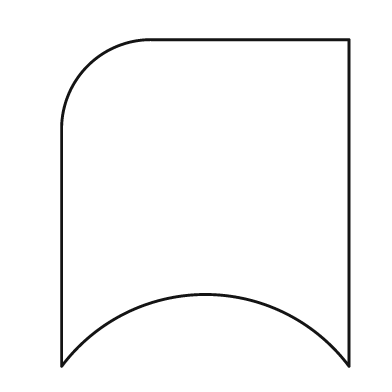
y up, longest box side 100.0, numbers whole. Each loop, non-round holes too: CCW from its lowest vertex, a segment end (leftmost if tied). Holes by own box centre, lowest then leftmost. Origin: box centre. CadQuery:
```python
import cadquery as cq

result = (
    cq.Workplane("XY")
    .moveTo(-44.0, -50.0)
    .threePointArc((0.0, -28.0), (44.0, -50.0))
    .lineTo(44.0, 50.0)
    .lineTo(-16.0, 50.0)
    .threePointArc((-36.0, 42.0), (-44.0, 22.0))
    .close()
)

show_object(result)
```